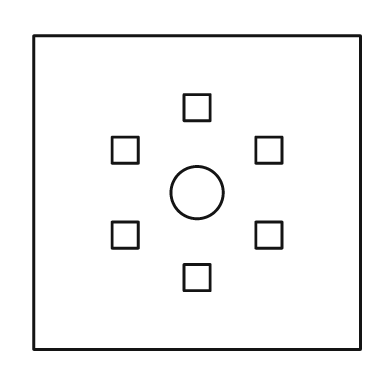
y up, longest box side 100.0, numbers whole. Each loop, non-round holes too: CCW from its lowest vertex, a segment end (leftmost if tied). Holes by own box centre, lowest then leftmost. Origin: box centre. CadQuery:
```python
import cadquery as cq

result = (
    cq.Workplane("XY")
    .moveTo(-50.0, -48.0)
    .lineTo(50.0, -48.0)
    .lineTo(50.0, 48.0)
    .lineTo(-50.0, 48.0)
    .close()
    .moveTo(-4.0, -30.0)
    .lineTo(4.0, -30.0)
    .lineTo(4.0, -22.0)
    .lineTo(-4.0, -22.0)
    .close()
    .moveTo(-26.0, -17.0)
    .lineTo(-18.0, -17.0)
    .lineTo(-18.0, -9.0)
    .lineTo(-26.0, -9.0)
    .close()
    .moveTo(18.0, -17.0)
    .lineTo(26.0, -17.0)
    .lineTo(26.0, -9.0)
    .lineTo(18.0, -9.0)
    .close()
    .moveTo(0.0, 0.0)
    .circle(8.0)
    .moveTo(-26.0, 9.0)
    .lineTo(-18.0, 9.0)
    .lineTo(-18.0, 17.0)
    .lineTo(-26.0, 17.0)
    .close()
    .moveTo(18.0, 9.0)
    .lineTo(26.0, 9.0)
    .lineTo(26.0, 17.0)
    .lineTo(18.0, 17.0)
    .close()
    .moveTo(-4.0, 22.0)
    .lineTo(4.0, 22.0)
    .lineTo(4.0, 30.0)
    .lineTo(-4.0, 30.0)
    .close()
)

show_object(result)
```